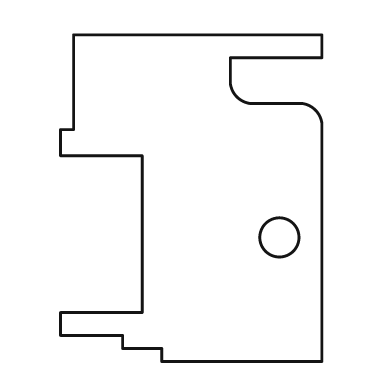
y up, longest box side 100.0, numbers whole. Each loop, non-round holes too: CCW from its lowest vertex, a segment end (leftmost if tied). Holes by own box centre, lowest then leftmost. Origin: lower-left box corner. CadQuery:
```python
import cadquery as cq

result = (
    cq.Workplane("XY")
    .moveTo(31.0, 0.0)
    .lineTo(80.0, 0.0)
    .lineTo(80.0, 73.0)
    .threePointArc((78.0, 77.0), (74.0, 79.0))
    .lineTo(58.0, 79.0)
    .threePointArc((54.0, 81.0), (52.0, 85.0))
    .lineTo(52.0, 93.0)
    .lineTo(80.0, 93.0)
    .lineTo(80.0, 100.0)
    .lineTo(4.0, 100.0)
    .lineTo(4.0, 71.0)
    .lineTo(0.0, 71.0)
    .lineTo(0.0, 63.0)
    .lineTo(25.0, 63.0)
    .lineTo(25.0, 15.0)
    .lineTo(0.0, 15.0)
    .lineTo(0.0, 8.0)
    .lineTo(19.0, 8.0)
    .lineTo(19.0, 4.0)
    .lineTo(31.0, 4.0)
    .close()
    .moveTo(67.0, 38.0)
    .circle(6.0)
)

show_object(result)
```